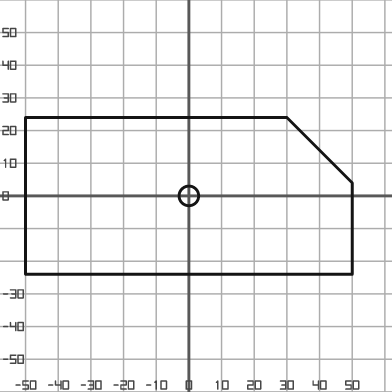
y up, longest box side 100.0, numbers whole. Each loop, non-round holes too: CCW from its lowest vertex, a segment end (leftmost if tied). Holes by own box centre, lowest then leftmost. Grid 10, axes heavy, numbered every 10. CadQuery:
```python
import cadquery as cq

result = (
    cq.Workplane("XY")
    .moveTo(-50.0, -24.0)
    .lineTo(50.0, -24.0)
    .lineTo(50.0, 4.0)
    .lineTo(30.0, 24.0)
    .lineTo(-50.0, 24.0)
    .close()
    .moveTo(0.0, 0.0)
    .circle(3.0)
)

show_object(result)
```